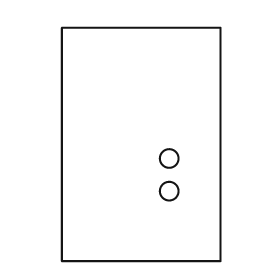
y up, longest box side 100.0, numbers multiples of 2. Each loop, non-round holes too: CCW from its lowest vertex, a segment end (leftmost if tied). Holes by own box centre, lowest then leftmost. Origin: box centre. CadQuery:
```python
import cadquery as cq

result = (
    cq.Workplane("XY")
    .moveTo(-34.0, -50.0)
    .lineTo(34.0, -50.0)
    .lineTo(34.0, 50.0)
    .lineTo(-34.0, 50.0)
    .close()
    .moveTo(12.0, -20.0)
    .circle(4.0)
    .moveTo(12.0, -6.0)
    .circle(4.0)
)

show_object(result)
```